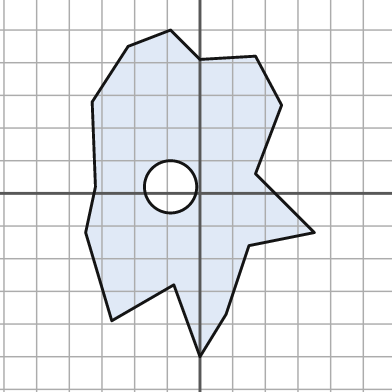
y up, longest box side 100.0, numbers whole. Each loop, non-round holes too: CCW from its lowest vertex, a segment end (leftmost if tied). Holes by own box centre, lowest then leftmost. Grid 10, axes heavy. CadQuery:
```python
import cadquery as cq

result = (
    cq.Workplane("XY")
    .moveTo(0.0, -50.0)
    .lineTo(8.0, -37.0)
    .lineTo(15.0, -16.0)
    .lineTo(35.0, -12.0)
    .lineTo(17.0, 6.0)
    .lineTo(25.0, 27.0)
    .lineTo(17.0, 42.0)
    .lineTo(0.0, 41.0)
    .lineTo(-9.0, 50.0)
    .lineTo(-22.0, 45.0)
    .lineTo(-33.0, 28.0)
    .lineTo(-32.0, 2.0)
    .lineTo(-35.0, -12.0)
    .lineTo(-27.0, -39.0)
    .lineTo(-8.0, -28.0)
    .close()
    .moveTo(-9.0, 2.0)
    .circle(8.0)
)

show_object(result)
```